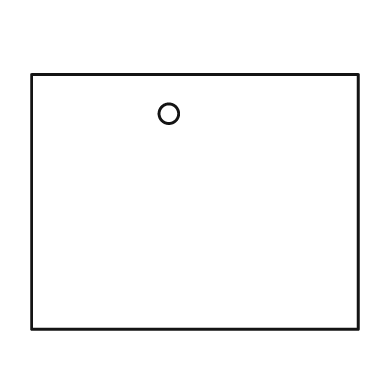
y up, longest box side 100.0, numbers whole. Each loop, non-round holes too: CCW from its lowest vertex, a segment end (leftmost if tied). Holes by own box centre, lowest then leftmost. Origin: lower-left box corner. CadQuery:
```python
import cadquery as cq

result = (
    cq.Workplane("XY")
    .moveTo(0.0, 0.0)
    .lineTo(100.0, 0.0)
    .lineTo(100.0, 78.0)
    .lineTo(0.0, 78.0)
    .close()
    .moveTo(42.0, 66.0)
    .circle(3.0)
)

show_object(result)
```